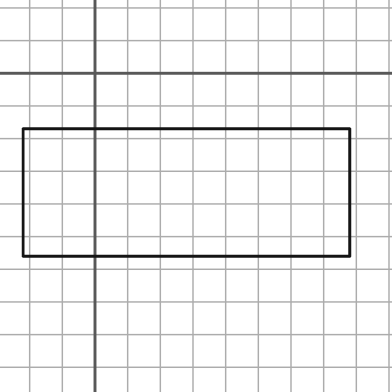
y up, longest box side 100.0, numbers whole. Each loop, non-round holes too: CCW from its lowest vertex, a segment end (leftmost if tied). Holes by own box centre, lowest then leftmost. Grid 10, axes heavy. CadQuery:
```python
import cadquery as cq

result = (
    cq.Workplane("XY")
    .moveTo(-22.0, -56.0)
    .lineTo(78.0, -56.0)
    .lineTo(78.0, -17.0)
    .lineTo(-22.0, -17.0)
    .close()
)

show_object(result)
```